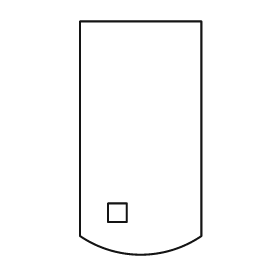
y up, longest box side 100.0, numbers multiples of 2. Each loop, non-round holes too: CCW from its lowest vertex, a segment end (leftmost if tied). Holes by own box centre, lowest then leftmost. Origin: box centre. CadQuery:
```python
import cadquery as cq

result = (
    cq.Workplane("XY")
    .moveTo(-26.0, -42.0)
    .threePointArc((0.0, -50.0), (26.0, -42.0))
    .lineTo(26.0, 50.0)
    .lineTo(-26.0, 50.0)
    .close()
    .moveTo(-14.0, -36.0)
    .lineTo(-6.0, -36.0)
    .lineTo(-6.0, -28.0)
    .lineTo(-14.0, -28.0)
    .close()
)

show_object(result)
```